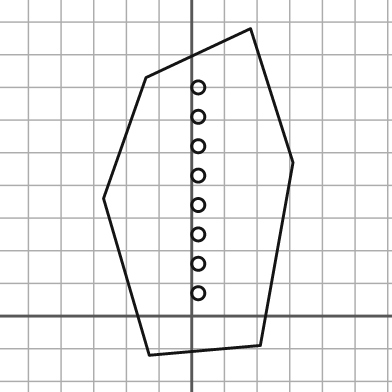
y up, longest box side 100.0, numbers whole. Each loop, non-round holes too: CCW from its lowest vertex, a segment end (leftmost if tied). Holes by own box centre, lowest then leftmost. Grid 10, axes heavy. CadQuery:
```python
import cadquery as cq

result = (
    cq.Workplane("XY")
    .moveTo(-13.0, -12.0)
    .lineTo(21.0, -9.0)
    .lineTo(31.0, 47.0)
    .lineTo(18.0, 88.0)
    .lineTo(-14.0, 73.0)
    .lineTo(-27.0, 36.0)
    .close()
    .moveTo(2.0, 7.0)
    .circle(2.0)
    .moveTo(2.0, 16.0)
    .circle(2.0)
    .moveTo(2.0, 25.0)
    .circle(2.0)
    .moveTo(2.0, 34.0)
    .circle(2.0)
    .moveTo(2.0, 43.0)
    .circle(2.0)
    .moveTo(2.0, 52.0)
    .circle(2.0)
    .moveTo(2.0, 61.0)
    .circle(2.0)
    .moveTo(2.0, 70.0)
    .circle(2.0)
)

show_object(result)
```